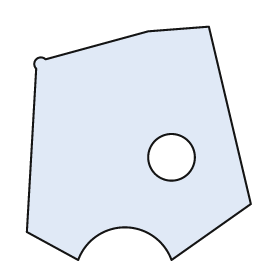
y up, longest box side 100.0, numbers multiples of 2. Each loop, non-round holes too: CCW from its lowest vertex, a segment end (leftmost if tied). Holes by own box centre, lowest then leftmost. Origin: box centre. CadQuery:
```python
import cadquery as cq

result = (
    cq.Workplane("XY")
    .moveTo(-26.0, -50.0)
    .threePointArc((-6.0, -36.0), (14.0, -50.0))
    .lineTo(48.0, -26.0)
    .lineTo(30.0, 50.0)
    .lineTo(4.0, 48.0)
    .lineTo(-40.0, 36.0)
    .threePointArc((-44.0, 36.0), (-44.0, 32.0))
    .lineTo(-48.0, -38.0)
    .close()
    .moveTo(14.0, -6.0)
    .circle(10.0)
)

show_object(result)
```